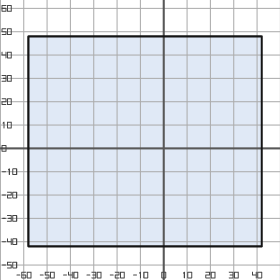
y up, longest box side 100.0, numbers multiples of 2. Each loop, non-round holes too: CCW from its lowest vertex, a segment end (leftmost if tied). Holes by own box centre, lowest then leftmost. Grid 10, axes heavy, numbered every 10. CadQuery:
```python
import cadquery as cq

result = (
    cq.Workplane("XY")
    .moveTo(-58.0, -42.0)
    .lineTo(42.0, -42.0)
    .lineTo(42.0, 48.0)
    .lineTo(-58.0, 48.0)
    .close()
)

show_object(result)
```